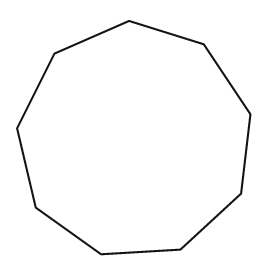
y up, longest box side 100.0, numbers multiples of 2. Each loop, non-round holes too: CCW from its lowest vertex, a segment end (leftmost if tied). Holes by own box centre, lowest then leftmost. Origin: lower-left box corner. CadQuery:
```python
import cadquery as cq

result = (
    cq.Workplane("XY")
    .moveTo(36.0, 0.0)
    .lineTo(70.0, 2.0)
    .lineTo(96.0, 26.0)
    .lineTo(100.0, 60.0)
    .lineTo(80.0, 90.0)
    .lineTo(48.0, 100.0)
    .lineTo(16.0, 86.0)
    .lineTo(0.0, 54.0)
    .lineTo(8.0, 20.0)
    .close()
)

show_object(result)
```